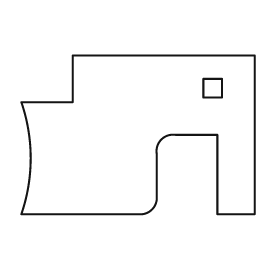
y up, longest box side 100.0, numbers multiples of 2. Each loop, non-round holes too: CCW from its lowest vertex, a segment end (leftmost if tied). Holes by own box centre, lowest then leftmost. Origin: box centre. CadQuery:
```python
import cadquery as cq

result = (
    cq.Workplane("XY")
    .moveTo(-50.0, -34.0)
    .lineTo(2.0, -34.0)
    .threePointArc((6.0, -32.0), (8.0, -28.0))
    .lineTo(8.0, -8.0)
    .threePointArc((10.0, -2.0), (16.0, 0.0))
    .lineTo(34.0, 0.0)
    .lineTo(34.0, -34.0)
    .lineTo(50.0, -34.0)
    .lineTo(50.0, 34.0)
    .lineTo(-28.0, 34.0)
    .lineTo(-28.0, 14.0)
    .lineTo(-50.0, 14.0)
    .threePointArc((-46.0, -10.0), (-50.0, -34.0))
    .close()
    .moveTo(28.0, 16.0)
    .lineTo(36.0, 16.0)
    .lineTo(36.0, 24.0)
    .lineTo(28.0, 24.0)
    .close()
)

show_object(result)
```